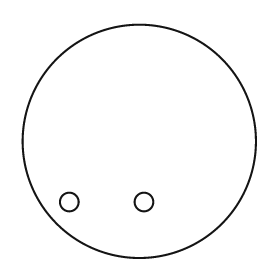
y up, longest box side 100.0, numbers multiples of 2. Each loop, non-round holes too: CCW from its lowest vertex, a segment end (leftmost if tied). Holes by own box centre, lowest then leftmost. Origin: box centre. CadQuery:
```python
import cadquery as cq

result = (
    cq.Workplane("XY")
    .moveTo(0.0, 0.0)
    .circle(50.0)
    .moveTo(-30.0, -26.0)
    .circle(4.0)
    .moveTo(2.0, -26.0)
    .circle(4.0)
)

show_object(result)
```